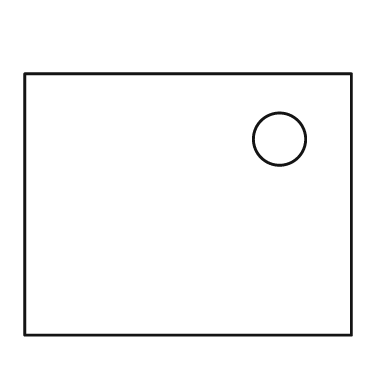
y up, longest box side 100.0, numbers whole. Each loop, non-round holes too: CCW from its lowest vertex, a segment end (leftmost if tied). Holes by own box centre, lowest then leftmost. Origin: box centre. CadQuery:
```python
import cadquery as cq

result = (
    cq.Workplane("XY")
    .moveTo(-50.0, -40.0)
    .lineTo(50.0, -40.0)
    .lineTo(50.0, 40.0)
    .lineTo(-50.0, 40.0)
    .close()
    .moveTo(28.0, 20.0)
    .circle(8.0)
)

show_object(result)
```